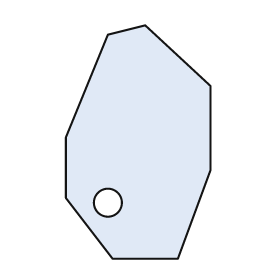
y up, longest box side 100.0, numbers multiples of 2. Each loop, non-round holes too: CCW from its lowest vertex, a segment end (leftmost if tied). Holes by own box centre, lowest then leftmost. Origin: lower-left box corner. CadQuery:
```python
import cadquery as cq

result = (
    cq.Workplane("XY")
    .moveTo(20.0, 0.0)
    .lineTo(48.0, 0.0)
    .lineTo(62.0, 38.0)
    .lineTo(62.0, 74.0)
    .lineTo(34.0, 100.0)
    .lineTo(18.0, 96.0)
    .lineTo(0.0, 52.0)
    .lineTo(0.0, 26.0)
    .close()
    .moveTo(18.0, 24.0)
    .circle(6.0)
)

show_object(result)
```